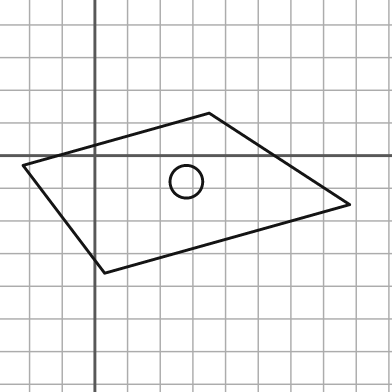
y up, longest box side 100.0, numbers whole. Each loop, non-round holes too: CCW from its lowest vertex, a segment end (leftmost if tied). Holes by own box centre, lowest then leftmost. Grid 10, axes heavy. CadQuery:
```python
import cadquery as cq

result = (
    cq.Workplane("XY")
    .moveTo(3.0, -36.0)
    .lineTo(78.0, -15.0)
    .lineTo(35.0, 13.0)
    .lineTo(-22.0, -3.0)
    .close()
    .moveTo(28.0, -8.0)
    .circle(5.0)
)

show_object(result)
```